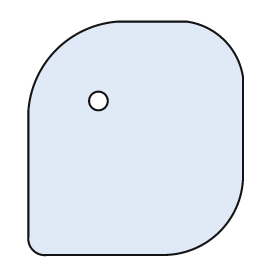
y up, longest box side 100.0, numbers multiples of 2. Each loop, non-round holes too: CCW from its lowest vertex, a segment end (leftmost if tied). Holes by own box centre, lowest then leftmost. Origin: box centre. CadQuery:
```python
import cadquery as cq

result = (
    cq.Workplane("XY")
    .moveTo(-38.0, -50.0)
    .lineTo(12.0, -50.0)
    .threePointArc((36.0, -40.0), (46.0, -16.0))
    .lineTo(46.0, 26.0)
    .threePointArc((38.0, 42.0), (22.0, 50.0))
    .lineTo(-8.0, 50.0)
    .threePointArc((-34.0, 38.0), (-46.0, 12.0))
    .lineTo(-46.0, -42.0)
    .threePointArc((-44.0, -48.0), (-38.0, -50.0))
    .close()
    .moveTo(-16.0, 16.0)
    .circle(4.0)
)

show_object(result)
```